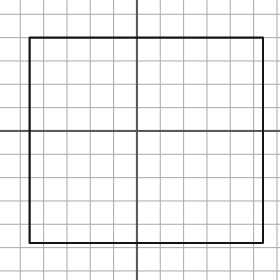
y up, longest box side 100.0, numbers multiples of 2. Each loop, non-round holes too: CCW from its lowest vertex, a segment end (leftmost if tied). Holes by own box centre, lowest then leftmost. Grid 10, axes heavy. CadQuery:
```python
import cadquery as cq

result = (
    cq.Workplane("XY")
    .moveTo(-46.0, -48.0)
    .lineTo(54.0, -48.0)
    .lineTo(54.0, 40.0)
    .lineTo(-46.0, 40.0)
    .close()
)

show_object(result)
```